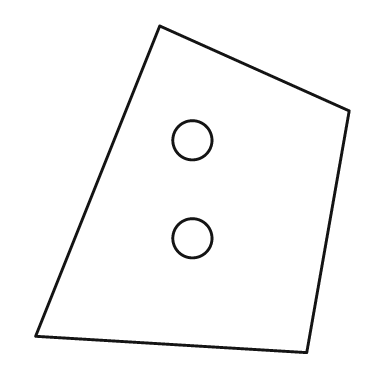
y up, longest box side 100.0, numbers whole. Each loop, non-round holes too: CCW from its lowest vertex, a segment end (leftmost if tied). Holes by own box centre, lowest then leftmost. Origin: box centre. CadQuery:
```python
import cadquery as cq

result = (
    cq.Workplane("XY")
    .moveTo(35.0, -50.0)
    .lineTo(48.0, 24.0)
    .lineTo(-10.0, 50.0)
    .lineTo(-48.0, -45.0)
    .close()
    .moveTo(0.0, -15.0)
    .circle(6.0)
    .moveTo(0.0, 15.0)
    .circle(6.0)
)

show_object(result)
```